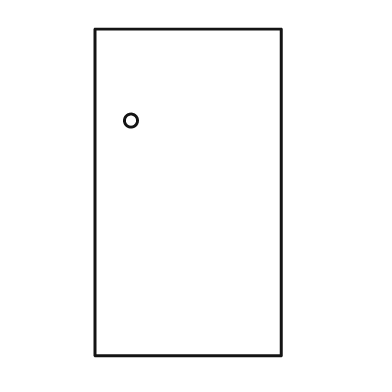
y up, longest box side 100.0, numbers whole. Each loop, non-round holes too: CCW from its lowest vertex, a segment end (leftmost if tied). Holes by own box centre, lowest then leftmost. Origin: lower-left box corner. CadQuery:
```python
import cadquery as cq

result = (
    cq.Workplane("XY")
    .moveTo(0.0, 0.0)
    .lineTo(57.0, 0.0)
    .lineTo(57.0, 100.0)
    .lineTo(0.0, 100.0)
    .close()
    .moveTo(11.0, 72.0)
    .circle(2.0)
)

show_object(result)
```